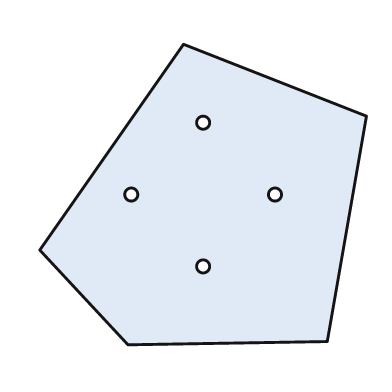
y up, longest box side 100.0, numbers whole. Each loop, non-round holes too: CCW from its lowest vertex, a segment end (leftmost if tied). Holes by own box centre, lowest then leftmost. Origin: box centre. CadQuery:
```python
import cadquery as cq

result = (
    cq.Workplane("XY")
    .moveTo(-23.0, -46.0)
    .lineTo(38.0, -45.0)
    .lineTo(50.0, 24.0)
    .lineTo(-6.0, 46.0)
    .lineTo(-50.0, -17.0)
    .close()
    .moveTo(0.0, -22.0)
    .circle(2.0)
    .moveTo(-22.0, 0.0)
    .circle(2.0)
    .moveTo(22.0, 0.0)
    .circle(2.0)
    .moveTo(0.0, 22.0)
    .circle(2.0)
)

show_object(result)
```